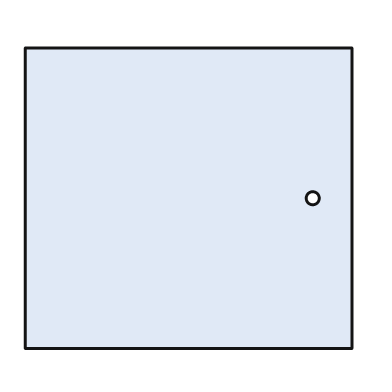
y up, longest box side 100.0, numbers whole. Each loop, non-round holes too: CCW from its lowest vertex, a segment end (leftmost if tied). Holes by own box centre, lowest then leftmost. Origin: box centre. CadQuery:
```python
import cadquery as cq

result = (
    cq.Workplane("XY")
    .moveTo(-50.0, -46.0)
    .lineTo(50.0, -46.0)
    .lineTo(50.0, 46.0)
    .lineTo(-50.0, 46.0)
    .close()
    .moveTo(38.0, 0.0)
    .circle(2.0)
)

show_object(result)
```